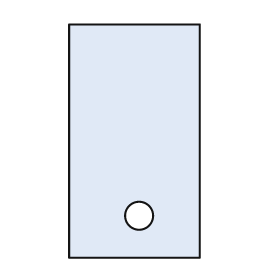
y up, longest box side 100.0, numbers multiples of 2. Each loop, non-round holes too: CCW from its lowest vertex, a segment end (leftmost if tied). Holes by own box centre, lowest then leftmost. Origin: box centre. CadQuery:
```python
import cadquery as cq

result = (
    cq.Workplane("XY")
    .moveTo(-28.0, -50.0)
    .lineTo(28.0, -50.0)
    .lineTo(28.0, 50.0)
    .lineTo(-28.0, 50.0)
    .close()
    .moveTo(2.0, -32.0)
    .circle(6.0)
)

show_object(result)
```